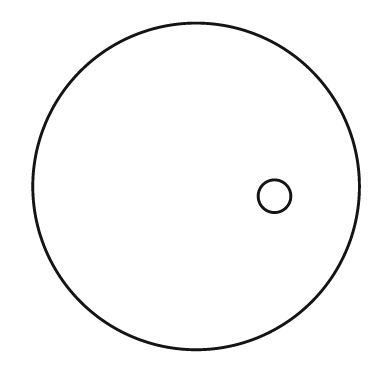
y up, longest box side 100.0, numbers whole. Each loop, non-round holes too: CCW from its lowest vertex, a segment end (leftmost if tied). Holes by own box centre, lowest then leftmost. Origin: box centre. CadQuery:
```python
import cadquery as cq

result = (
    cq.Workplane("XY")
    .moveTo(0.0, 0.0)
    .circle(50.0)
    .moveTo(24.0, -3.0)
    .circle(5.0)
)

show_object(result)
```